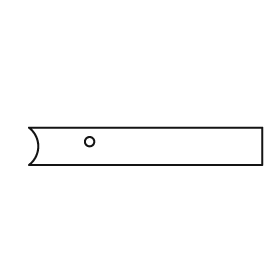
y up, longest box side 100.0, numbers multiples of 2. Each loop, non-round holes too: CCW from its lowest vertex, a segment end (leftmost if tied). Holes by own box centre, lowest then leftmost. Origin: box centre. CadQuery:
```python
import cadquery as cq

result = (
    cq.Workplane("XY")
    .moveTo(-50.0, -8.0)
    .lineTo(50.0, -8.0)
    .lineTo(50.0, 8.0)
    .lineTo(-50.0, 8.0)
    .threePointArc((-46.0, 0.0), (-50.0, -8.0))
    .close()
    .moveTo(-24.0, 2.0)
    .circle(2.0)
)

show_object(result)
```